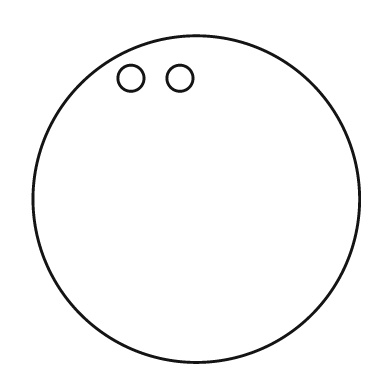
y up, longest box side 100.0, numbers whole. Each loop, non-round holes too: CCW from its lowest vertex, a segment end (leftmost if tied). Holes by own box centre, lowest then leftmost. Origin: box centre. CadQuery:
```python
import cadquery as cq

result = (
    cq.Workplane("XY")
    .moveTo(0.0, 0.0)
    .circle(50.0)
    .moveTo(-20.0, 37.0)
    .circle(4.0)
    .moveTo(-5.0, 37.0)
    .circle(4.0)
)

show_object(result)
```